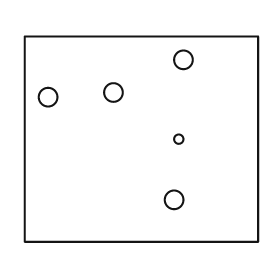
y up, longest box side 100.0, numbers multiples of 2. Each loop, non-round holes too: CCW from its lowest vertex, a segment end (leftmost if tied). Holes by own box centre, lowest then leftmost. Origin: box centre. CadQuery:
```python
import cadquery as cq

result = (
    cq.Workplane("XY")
    .moveTo(-50.0, -44.0)
    .lineTo(50.0, -44.0)
    .lineTo(50.0, 44.0)
    .lineTo(-50.0, 44.0)
    .close()
    .moveTo(14.0, -26.0)
    .circle(4.0)
    .moveTo(16.0, 0.0)
    .circle(2.0)
    .moveTo(-40.0, 18.0)
    .circle(4.0)
    .moveTo(-12.0, 20.0)
    .circle(4.0)
    .moveTo(18.0, 34.0)
    .circle(4.0)
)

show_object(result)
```